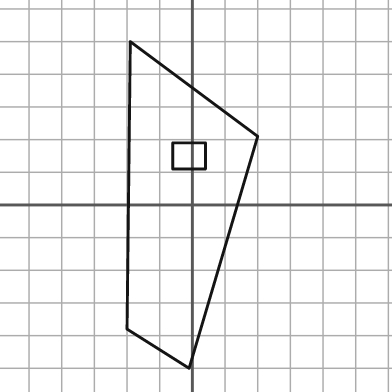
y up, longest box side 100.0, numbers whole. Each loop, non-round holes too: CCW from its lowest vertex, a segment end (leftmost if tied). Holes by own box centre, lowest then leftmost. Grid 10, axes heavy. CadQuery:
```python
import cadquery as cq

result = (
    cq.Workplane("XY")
    .moveTo(-1.0, -50.0)
    .lineTo(20.0, 21.0)
    .lineTo(-19.0, 50.0)
    .lineTo(-20.0, -38.0)
    .close()
    .moveTo(-6.0, 11.0)
    .lineTo(4.0, 11.0)
    .lineTo(4.0, 19.0)
    .lineTo(-6.0, 19.0)
    .close()
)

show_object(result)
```